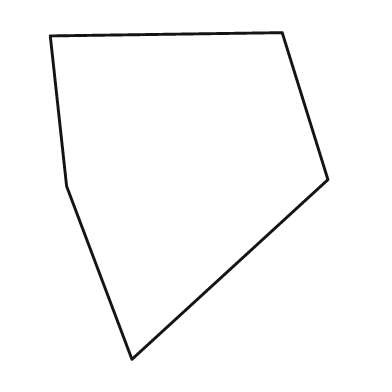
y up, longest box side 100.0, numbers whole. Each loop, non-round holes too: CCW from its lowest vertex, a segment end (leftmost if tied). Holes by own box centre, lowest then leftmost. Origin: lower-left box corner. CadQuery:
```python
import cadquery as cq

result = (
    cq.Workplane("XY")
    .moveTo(25.0, 0.0)
    .lineTo(85.0, 55.0)
    .lineTo(71.0, 100.0)
    .lineTo(0.0, 99.0)
    .lineTo(5.0, 53.0)
    .close()
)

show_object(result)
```